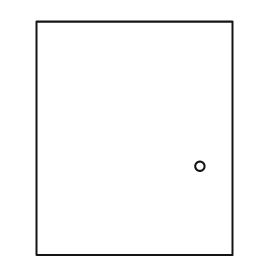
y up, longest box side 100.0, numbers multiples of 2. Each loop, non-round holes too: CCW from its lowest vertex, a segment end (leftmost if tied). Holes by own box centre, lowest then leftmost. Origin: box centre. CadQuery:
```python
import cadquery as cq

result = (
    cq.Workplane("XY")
    .moveTo(-42.0, -50.0)
    .lineTo(42.0, -50.0)
    .lineTo(42.0, 50.0)
    .lineTo(-42.0, 50.0)
    .close()
    .moveTo(28.0, -12.0)
    .circle(2.0)
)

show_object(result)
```